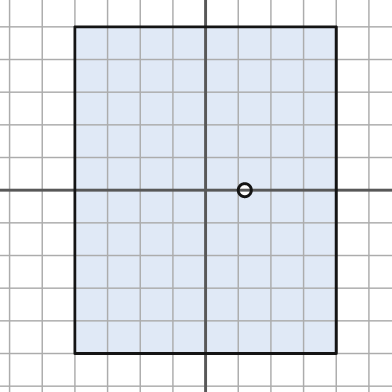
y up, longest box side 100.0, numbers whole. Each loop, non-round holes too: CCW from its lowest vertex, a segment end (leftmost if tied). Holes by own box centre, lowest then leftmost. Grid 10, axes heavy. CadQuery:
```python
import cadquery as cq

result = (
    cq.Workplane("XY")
    .moveTo(-40.0, -50.0)
    .lineTo(40.0, -50.0)
    .lineTo(40.0, 50.0)
    .lineTo(-40.0, 50.0)
    .close()
    .moveTo(12.0, 0.0)
    .circle(2.0)
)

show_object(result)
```